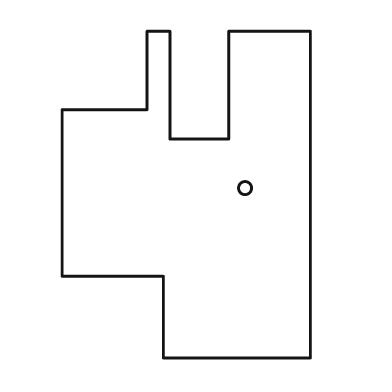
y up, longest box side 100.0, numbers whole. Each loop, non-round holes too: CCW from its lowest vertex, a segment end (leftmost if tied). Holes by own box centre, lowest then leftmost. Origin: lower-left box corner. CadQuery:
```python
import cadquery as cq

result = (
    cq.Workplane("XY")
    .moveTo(31.0, 0.0)
    .lineTo(76.0, 0.0)
    .lineTo(76.0, 100.0)
    .lineTo(51.0, 100.0)
    .lineTo(51.0, 67.0)
    .lineTo(33.0, 67.0)
    .lineTo(33.0, 100.0)
    .lineTo(26.0, 100.0)
    .lineTo(26.0, 76.0)
    .lineTo(0.0, 76.0)
    .lineTo(0.0, 25.0)
    .lineTo(31.0, 25.0)
    .close()
    .moveTo(56.0, 52.0)
    .circle(2.0)
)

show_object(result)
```